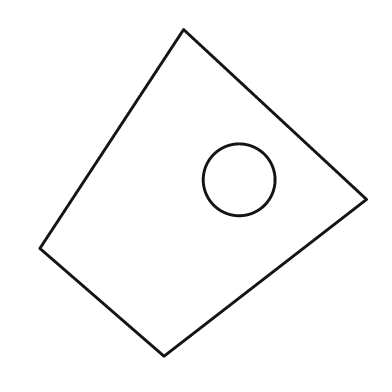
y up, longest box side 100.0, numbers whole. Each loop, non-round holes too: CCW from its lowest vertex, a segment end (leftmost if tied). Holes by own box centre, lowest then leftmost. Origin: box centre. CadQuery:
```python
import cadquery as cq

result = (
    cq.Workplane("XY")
    .moveTo(-12.0, -50.0)
    .lineTo(50.0, -2.0)
    .lineTo(-6.0, 50.0)
    .lineTo(-50.0, -17.0)
    .close()
    .moveTo(11.0, 4.0)
    .circle(11.0)
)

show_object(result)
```